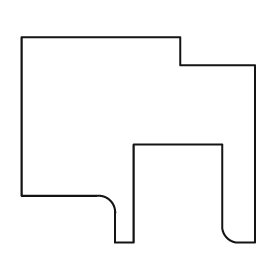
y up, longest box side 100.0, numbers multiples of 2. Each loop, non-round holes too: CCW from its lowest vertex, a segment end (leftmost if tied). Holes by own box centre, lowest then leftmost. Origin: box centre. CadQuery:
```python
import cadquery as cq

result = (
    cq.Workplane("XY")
    .moveTo(-10.0, -44.0)
    .lineTo(-2.0, -44.0)
    .lineTo(-2.0, -2.0)
    .lineTo(36.0, -2.0)
    .lineTo(36.0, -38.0)
    .threePointArc((38.0, -42.0), (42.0, -44.0))
    .lineTo(50.0, -44.0)
    .lineTo(50.0, 32.0)
    .lineTo(18.0, 32.0)
    .lineTo(18.0, 44.0)
    .lineTo(-50.0, 44.0)
    .lineTo(-50.0, -24.0)
    .lineTo(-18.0, -24.0)
    .threePointArc((-12.0, -26.0), (-10.0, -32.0))
    .close()
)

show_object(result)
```